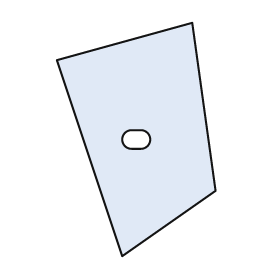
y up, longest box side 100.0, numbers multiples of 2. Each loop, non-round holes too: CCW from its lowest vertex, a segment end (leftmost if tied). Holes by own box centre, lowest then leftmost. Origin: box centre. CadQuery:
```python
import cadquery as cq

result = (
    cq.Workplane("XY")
    .moveTo(-6.0, -50.0)
    .lineTo(34.0, -22.0)
    .lineTo(24.0, 50.0)
    .lineTo(-34.0, 34.0)
    .close()
    .moveTo(-2.0, -4.0)
    .lineTo(2.0, -4.0)
    .threePointArc((6.0, 0.0), (2.0, 4.0))
    .lineTo(-2.0, 4.0)
    .threePointArc((-6.0, 0.0), (-2.0, -4.0))
    .close()
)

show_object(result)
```